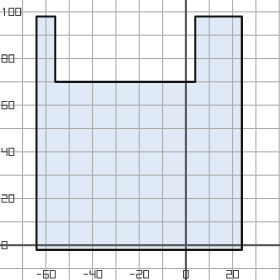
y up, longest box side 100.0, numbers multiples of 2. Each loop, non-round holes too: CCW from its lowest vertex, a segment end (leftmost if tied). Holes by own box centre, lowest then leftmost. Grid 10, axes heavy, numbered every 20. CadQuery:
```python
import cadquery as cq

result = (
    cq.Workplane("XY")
    .moveTo(-64.0, -2.0)
    .lineTo(24.0, -2.0)
    .lineTo(24.0, 98.0)
    .lineTo(4.0, 98.0)
    .lineTo(4.0, 70.0)
    .lineTo(-56.0, 70.0)
    .lineTo(-56.0, 98.0)
    .lineTo(-64.0, 98.0)
    .close()
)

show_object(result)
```